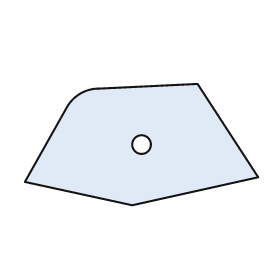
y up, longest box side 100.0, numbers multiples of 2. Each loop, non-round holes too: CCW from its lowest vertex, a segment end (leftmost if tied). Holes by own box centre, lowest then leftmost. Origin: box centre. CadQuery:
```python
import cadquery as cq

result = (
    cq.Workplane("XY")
    .moveTo(-4.0, -26.0)
    .lineTo(50.0, -14.0)
    .lineTo(24.0, 26.0)
    .lineTo(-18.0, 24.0)
    .threePointArc((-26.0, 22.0), (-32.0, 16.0))
    .lineTo(-50.0, -16.0)
    .close()
    .moveTo(0.0, 0.0)
    .circle(4.0)
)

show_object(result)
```